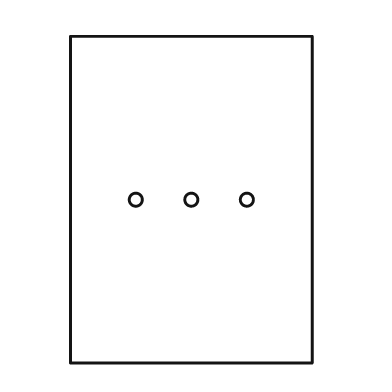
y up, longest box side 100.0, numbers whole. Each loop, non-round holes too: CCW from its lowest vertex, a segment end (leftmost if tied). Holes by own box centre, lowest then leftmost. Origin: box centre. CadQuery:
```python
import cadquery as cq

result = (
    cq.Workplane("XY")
    .moveTo(-37.0, -50.0)
    .lineTo(37.0, -50.0)
    .lineTo(37.0, 50.0)
    .lineTo(-37.0, 50.0)
    .close()
    .moveTo(-17.0, 0.0)
    .circle(2.0)
    .moveTo(0.0, 0.0)
    .circle(2.0)
    .moveTo(17.0, 0.0)
    .circle(2.0)
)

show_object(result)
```